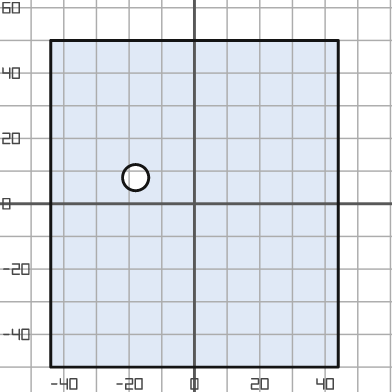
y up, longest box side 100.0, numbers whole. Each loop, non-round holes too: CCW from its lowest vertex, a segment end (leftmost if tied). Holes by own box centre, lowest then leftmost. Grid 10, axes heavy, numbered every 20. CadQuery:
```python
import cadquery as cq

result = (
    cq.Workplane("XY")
    .moveTo(-44.0, -50.0)
    .lineTo(44.0, -50.0)
    .lineTo(44.0, 50.0)
    .lineTo(-44.0, 50.0)
    .close()
    .moveTo(-18.0, 8.0)
    .circle(4.0)
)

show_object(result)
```